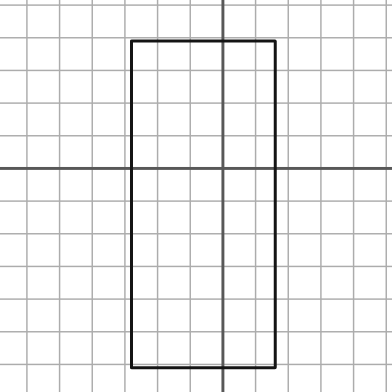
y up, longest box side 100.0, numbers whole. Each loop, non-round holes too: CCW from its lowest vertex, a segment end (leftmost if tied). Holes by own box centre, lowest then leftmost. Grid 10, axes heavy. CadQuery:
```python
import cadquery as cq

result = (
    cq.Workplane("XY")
    .moveTo(-28.0, -61.0)
    .lineTo(16.0, -61.0)
    .lineTo(16.0, 39.0)
    .lineTo(-28.0, 39.0)
    .close()
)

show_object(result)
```